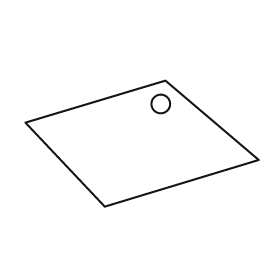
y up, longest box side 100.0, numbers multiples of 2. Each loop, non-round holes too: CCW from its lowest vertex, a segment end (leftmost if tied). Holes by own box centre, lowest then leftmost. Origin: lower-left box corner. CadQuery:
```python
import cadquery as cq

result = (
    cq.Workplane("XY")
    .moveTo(34.0, 0.0)
    .lineTo(100.0, 20.0)
    .lineTo(60.0, 54.0)
    .lineTo(0.0, 36.0)
    .close()
    .moveTo(58.0, 44.0)
    .circle(4.0)
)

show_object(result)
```